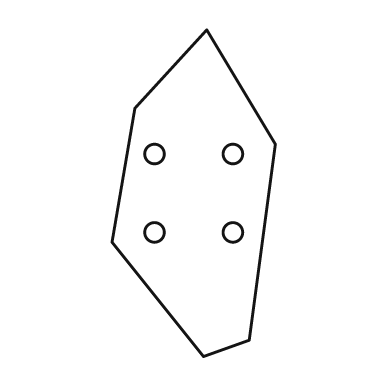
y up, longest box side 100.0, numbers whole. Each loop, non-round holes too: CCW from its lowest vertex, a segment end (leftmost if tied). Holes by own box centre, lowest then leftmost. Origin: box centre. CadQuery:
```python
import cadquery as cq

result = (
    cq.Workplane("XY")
    .moveTo(3.0, -50.0)
    .lineTo(17.0, -45.0)
    .lineTo(25.0, 15.0)
    .lineTo(4.0, 50.0)
    .lineTo(-18.0, 26.0)
    .lineTo(-25.0, -15.0)
    .close()
    .moveTo(-12.0, -12.0)
    .circle(3.0)
    .moveTo(12.0, -12.0)
    .circle(3.0)
    .moveTo(-12.0, 12.0)
    .circle(3.0)
    .moveTo(12.0, 12.0)
    .circle(3.0)
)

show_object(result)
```